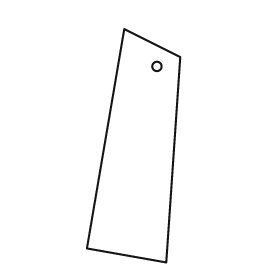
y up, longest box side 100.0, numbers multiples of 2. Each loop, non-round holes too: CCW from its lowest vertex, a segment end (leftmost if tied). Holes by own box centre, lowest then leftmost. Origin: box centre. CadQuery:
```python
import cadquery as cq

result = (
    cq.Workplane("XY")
    .moveTo(14.0, -50.0)
    .lineTo(20.0, 38.0)
    .lineTo(-4.0, 50.0)
    .lineTo(-20.0, -44.0)
    .close()
    .moveTo(10.0, 34.0)
    .circle(2.0)
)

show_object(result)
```